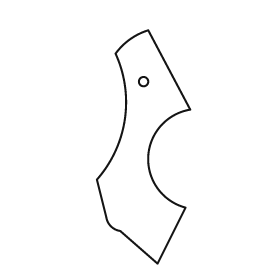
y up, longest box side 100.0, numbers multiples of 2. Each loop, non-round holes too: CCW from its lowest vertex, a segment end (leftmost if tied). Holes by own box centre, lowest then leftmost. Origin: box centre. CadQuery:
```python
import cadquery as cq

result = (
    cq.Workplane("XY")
    .moveTo(6.0, -50.0)
    .lineTo(18.0, -26.0)
    .threePointArc((2.0, -4.0), (20.0, 16.0))
    .lineTo(2.0, 50.0)
    .threePointArc((-6.0, 46.0), (-12.0, 40.0))
    .threePointArc((-8.0, 12.0), (-20.0, -14.0))
    .lineTo(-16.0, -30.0)
    .threePointArc((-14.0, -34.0), (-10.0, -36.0))
    .close()
    .moveTo(0.0, 28.0)
    .circle(2.0)
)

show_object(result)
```